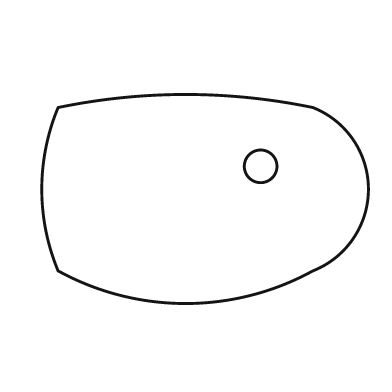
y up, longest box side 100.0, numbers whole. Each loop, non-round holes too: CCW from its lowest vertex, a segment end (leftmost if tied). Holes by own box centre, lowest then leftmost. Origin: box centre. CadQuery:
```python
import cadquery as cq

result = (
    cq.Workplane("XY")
    .moveTo(-45.0, -22.0)
    .threePointArc((-6.0, -32.0), (33.0, -22.0))
    .threePointArc((50.0, 3.0), (33.0, 28.0))
    .threePointArc((-6.0, 32.0), (-45.0, 28.0))
    .threePointArc((-50.0, 3.0), (-45.0, -22.0))
    .close()
    .moveTo(17.0, 10.0)
    .circle(5.0)
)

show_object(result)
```